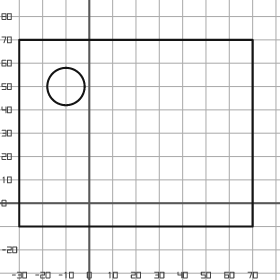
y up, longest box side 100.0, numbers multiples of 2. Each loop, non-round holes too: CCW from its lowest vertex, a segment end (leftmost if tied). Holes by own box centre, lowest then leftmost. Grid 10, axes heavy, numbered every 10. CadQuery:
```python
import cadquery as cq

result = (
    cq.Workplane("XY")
    .moveTo(-30.0, -10.0)
    .lineTo(70.0, -10.0)
    .lineTo(70.0, 70.0)
    .lineTo(-30.0, 70.0)
    .close()
    .moveTo(-10.0, 50.0)
    .circle(8.0)
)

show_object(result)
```